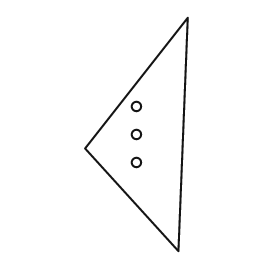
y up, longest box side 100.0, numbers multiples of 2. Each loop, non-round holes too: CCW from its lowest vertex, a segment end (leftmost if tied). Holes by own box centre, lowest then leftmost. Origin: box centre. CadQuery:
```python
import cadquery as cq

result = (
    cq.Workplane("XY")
    .moveTo(18.0, -50.0)
    .lineTo(22.0, 50.0)
    .lineTo(-22.0, -6.0)
    .close()
    .moveTo(0.0, -12.0)
    .circle(2.0)
    .moveTo(0.0, 0.0)
    .circle(2.0)
    .moveTo(0.0, 12.0)
    .circle(2.0)
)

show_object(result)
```